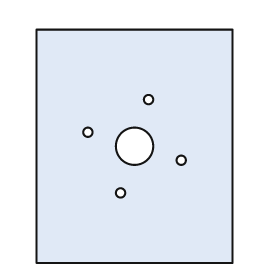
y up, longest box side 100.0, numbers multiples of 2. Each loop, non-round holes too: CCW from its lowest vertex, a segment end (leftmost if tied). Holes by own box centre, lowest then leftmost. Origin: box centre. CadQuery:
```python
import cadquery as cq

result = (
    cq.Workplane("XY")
    .moveTo(-42.0, -50.0)
    .lineTo(42.0, -50.0)
    .lineTo(42.0, 50.0)
    .lineTo(-42.0, 50.0)
    .close()
    .moveTo(-6.0, -20.0)
    .circle(2.0)
    .moveTo(20.0, -6.0)
    .circle(2.0)
    .moveTo(0.0, 0.0)
    .circle(8.0)
    .moveTo(-20.0, 6.0)
    .circle(2.0)
    .moveTo(6.0, 20.0)
    .circle(2.0)
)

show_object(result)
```